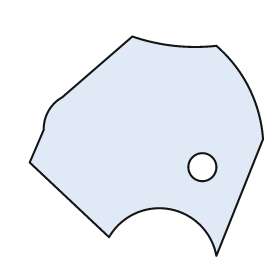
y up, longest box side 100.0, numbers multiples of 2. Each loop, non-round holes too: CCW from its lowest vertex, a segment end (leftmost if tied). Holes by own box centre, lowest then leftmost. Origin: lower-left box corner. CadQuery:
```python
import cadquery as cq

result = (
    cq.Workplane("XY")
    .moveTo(80.0, 0.0)
    .lineTo(100.0, 50.0)
    .threePointArc((94.0, 72.0), (80.0, 90.0))
    .threePointArc((62.0, 90.0), (44.0, 94.0))
    .lineTo(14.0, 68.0)
    .threePointArc((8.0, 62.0), (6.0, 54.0))
    .lineTo(0.0, 40.0)
    .lineTo(34.0, 8.0)
    .threePointArc((60.0, 20.0), (80.0, 0.0))
    .close()
    .moveTo(74.0, 38.0)
    .circle(6.0)
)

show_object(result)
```